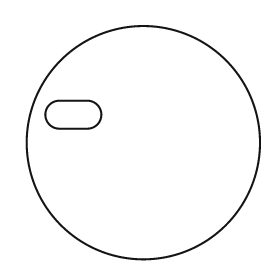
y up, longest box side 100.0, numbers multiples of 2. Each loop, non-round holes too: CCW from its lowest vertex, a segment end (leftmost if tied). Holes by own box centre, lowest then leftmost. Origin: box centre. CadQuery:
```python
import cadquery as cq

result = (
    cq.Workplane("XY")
    .moveTo(0.0, 0.0)
    .circle(50.0)
    .moveTo(-36.0, 6.0)
    .lineTo(-24.0, 6.0)
    .threePointArc((-18.0, 12.0), (-24.0, 18.0))
    .lineTo(-36.0, 18.0)
    .threePointArc((-42.0, 12.0), (-36.0, 6.0))
    .close()
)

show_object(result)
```